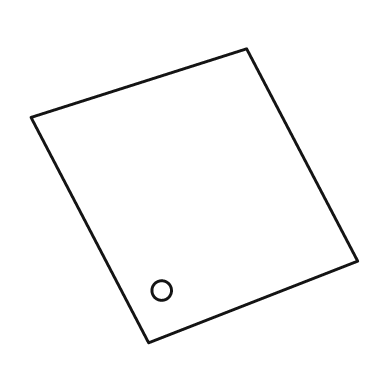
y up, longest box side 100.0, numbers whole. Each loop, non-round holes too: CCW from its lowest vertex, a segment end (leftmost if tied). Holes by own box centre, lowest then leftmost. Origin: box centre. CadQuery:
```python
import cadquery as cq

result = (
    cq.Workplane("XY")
    .moveTo(-14.0, -45.0)
    .lineTo(50.0, -20.0)
    .lineTo(16.0, 45.0)
    .lineTo(-50.0, 24.0)
    .close()
    .moveTo(-10.0, -29.0)
    .circle(3.0)
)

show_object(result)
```